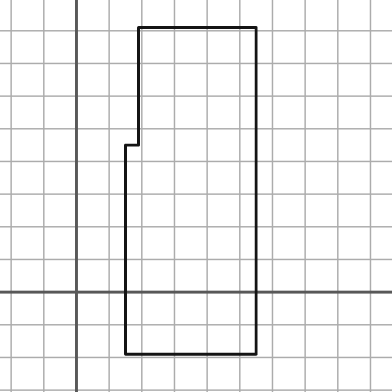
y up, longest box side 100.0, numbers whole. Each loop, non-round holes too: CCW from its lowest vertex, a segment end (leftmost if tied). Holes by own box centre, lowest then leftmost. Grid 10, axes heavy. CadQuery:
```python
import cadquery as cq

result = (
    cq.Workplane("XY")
    .moveTo(15.0, -19.0)
    .lineTo(55.0, -19.0)
    .lineTo(55.0, 81.0)
    .lineTo(19.0, 81.0)
    .lineTo(19.0, 45.0)
    .lineTo(15.0, 45.0)
    .close()
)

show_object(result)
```